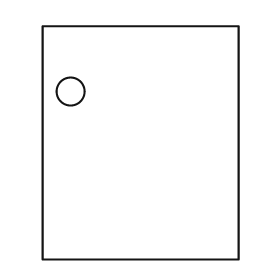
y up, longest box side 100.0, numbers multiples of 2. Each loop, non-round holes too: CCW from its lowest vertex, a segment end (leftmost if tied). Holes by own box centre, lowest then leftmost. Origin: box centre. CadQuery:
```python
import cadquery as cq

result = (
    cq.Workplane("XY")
    .moveTo(-42.0, -50.0)
    .lineTo(42.0, -50.0)
    .lineTo(42.0, 50.0)
    .lineTo(-42.0, 50.0)
    .close()
    .moveTo(-30.0, 22.0)
    .circle(6.0)
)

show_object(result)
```